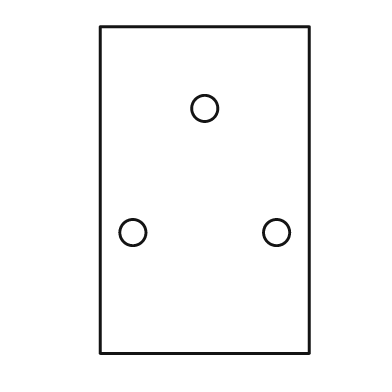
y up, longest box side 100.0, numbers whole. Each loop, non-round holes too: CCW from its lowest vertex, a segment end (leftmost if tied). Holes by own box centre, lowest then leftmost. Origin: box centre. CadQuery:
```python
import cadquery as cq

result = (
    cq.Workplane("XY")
    .moveTo(-32.0, -50.0)
    .lineTo(32.0, -50.0)
    .lineTo(32.0, 50.0)
    .lineTo(-32.0, 50.0)
    .close()
    .moveTo(-22.0, -13.0)
    .circle(4.0)
    .moveTo(22.0, -13.0)
    .circle(4.0)
    .moveTo(0.0, 25.0)
    .circle(4.0)
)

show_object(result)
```